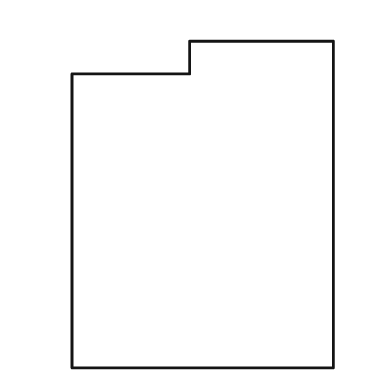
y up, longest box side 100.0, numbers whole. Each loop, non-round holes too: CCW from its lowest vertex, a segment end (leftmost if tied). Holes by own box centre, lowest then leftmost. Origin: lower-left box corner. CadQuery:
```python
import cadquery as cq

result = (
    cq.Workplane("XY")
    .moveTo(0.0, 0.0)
    .lineTo(80.0, 0.0)
    .lineTo(80.0, 100.0)
    .lineTo(36.0, 100.0)
    .lineTo(36.0, 90.0)
    .lineTo(0.0, 90.0)
    .close()
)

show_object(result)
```